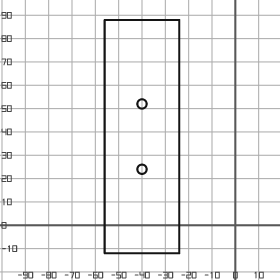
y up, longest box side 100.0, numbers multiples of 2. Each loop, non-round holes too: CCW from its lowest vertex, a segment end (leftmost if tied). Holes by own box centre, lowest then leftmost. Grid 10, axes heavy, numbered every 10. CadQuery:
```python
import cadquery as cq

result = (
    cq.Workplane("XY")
    .moveTo(-56.0, -12.0)
    .lineTo(-24.0, -12.0)
    .lineTo(-24.0, 88.0)
    .lineTo(-56.0, 88.0)
    .close()
    .moveTo(-40.0, 24.0)
    .circle(2.0)
    .moveTo(-40.0, 52.0)
    .circle(2.0)
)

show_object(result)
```